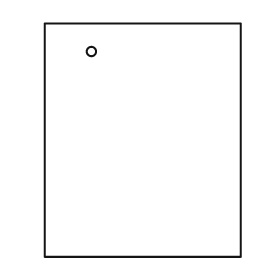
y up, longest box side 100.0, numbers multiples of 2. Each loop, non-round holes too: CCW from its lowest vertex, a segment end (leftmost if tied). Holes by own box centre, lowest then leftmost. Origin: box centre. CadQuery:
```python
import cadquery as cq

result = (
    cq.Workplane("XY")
    .moveTo(-42.0, -50.0)
    .lineTo(42.0, -50.0)
    .lineTo(42.0, 50.0)
    .lineTo(-42.0, 50.0)
    .close()
    .moveTo(-22.0, 38.0)
    .circle(2.0)
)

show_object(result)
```